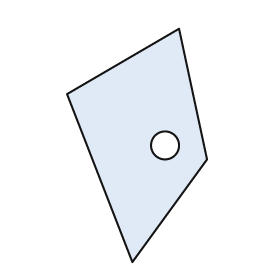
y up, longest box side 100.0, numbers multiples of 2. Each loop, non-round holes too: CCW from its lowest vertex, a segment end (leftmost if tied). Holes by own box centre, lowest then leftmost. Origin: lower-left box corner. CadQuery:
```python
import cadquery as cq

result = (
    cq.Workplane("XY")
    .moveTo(28.0, 0.0)
    .lineTo(60.0, 44.0)
    .lineTo(48.0, 100.0)
    .lineTo(0.0, 72.0)
    .close()
    .moveTo(42.0, 50.0)
    .circle(6.0)
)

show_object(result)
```